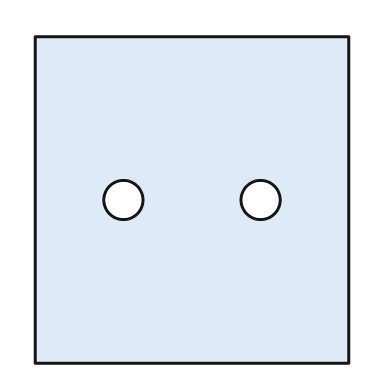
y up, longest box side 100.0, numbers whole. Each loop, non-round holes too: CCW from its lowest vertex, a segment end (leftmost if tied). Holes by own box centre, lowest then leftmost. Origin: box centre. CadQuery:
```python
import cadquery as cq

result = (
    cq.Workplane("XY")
    .moveTo(-48.0, -50.0)
    .lineTo(48.0, -50.0)
    .lineTo(48.0, 50.0)
    .lineTo(-48.0, 50.0)
    .close()
    .moveTo(-21.0, 0.0)
    .circle(6.0)
    .moveTo(21.0, 0.0)
    .circle(6.0)
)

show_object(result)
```